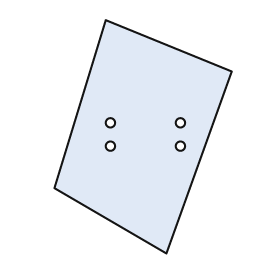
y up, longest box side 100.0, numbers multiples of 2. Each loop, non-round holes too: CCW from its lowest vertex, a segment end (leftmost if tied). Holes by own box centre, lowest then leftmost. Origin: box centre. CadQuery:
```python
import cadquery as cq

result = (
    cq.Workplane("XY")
    .moveTo(10.0, -50.0)
    .lineTo(38.0, 28.0)
    .lineTo(-16.0, 50.0)
    .lineTo(-38.0, -22.0)
    .close()
    .moveTo(-14.0, -4.0)
    .circle(2.0)
    .moveTo(16.0, -4.0)
    .circle(2.0)
    .moveTo(-14.0, 6.0)
    .circle(2.0)
    .moveTo(16.0, 6.0)
    .circle(2.0)
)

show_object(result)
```